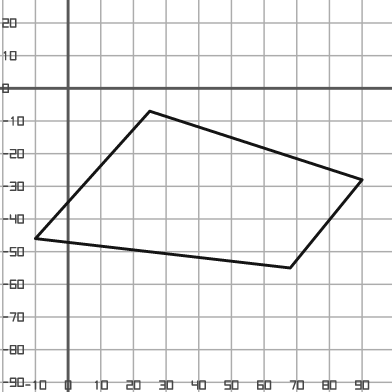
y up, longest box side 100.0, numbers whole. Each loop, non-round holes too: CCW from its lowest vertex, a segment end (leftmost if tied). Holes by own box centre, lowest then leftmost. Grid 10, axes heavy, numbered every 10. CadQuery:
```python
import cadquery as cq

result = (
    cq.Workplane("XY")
    .moveTo(68.0, -55.0)
    .lineTo(90.0, -28.0)
    .lineTo(25.0, -7.0)
    .lineTo(-10.0, -46.0)
    .close()
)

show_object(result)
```